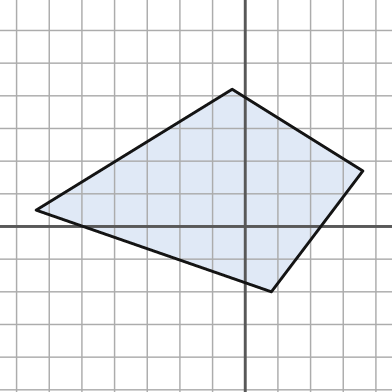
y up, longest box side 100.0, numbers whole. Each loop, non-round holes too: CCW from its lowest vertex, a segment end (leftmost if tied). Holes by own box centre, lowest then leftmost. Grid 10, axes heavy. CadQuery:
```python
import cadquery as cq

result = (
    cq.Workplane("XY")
    .moveTo(8.0, -20.0)
    .lineTo(36.0, 17.0)
    .lineTo(-4.0, 42.0)
    .lineTo(-64.0, 5.0)
    .close()
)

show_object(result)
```